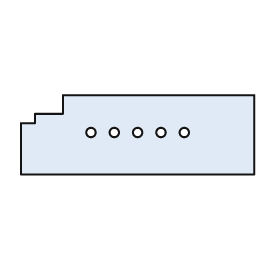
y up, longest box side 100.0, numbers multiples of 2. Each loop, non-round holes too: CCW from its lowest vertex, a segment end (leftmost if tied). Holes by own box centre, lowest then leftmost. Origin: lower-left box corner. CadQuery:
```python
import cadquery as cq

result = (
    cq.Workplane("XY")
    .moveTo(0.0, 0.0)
    .lineTo(100.0, 0.0)
    .lineTo(100.0, 34.0)
    .lineTo(18.0, 34.0)
    .lineTo(18.0, 26.0)
    .lineTo(6.0, 26.0)
    .lineTo(6.0, 22.0)
    .lineTo(0.0, 22.0)
    .close()
    .moveTo(30.0, 18.0)
    .circle(2.0)
    .moveTo(40.0, 18.0)
    .circle(2.0)
    .moveTo(50.0, 18.0)
    .circle(2.0)
    .moveTo(60.0, 18.0)
    .circle(2.0)
    .moveTo(70.0, 18.0)
    .circle(2.0)
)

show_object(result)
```